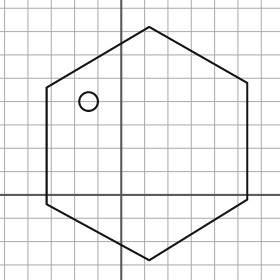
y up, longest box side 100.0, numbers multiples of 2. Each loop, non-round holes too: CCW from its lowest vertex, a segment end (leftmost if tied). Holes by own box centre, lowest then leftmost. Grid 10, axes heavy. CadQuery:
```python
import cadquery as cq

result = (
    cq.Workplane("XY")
    .moveTo(12.0, -28.0)
    .lineTo(54.0, -2.0)
    .lineTo(54.0, 48.0)
    .lineTo(12.0, 72.0)
    .lineTo(-32.0, 46.0)
    .lineTo(-32.0, -4.0)
    .close()
    .moveTo(-14.0, 40.0)
    .circle(4.0)
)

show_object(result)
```